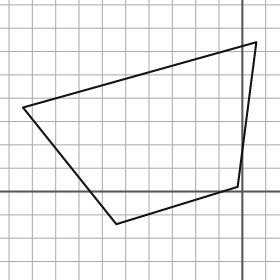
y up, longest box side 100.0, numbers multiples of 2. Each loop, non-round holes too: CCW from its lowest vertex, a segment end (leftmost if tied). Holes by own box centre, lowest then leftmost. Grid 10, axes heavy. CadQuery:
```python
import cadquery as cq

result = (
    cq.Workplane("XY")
    .moveTo(-54.0, -14.0)
    .lineTo(-2.0, 2.0)
    .lineTo(6.0, 64.0)
    .lineTo(-94.0, 36.0)
    .close()
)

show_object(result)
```